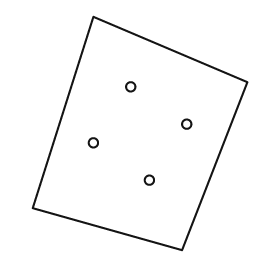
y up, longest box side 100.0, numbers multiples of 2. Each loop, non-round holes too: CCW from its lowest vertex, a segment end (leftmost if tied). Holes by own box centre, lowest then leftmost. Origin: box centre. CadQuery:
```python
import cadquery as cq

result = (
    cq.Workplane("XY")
    .moveTo(18.0, -50.0)
    .lineTo(46.0, 22.0)
    .lineTo(-20.0, 50.0)
    .lineTo(-46.0, -32.0)
    .close()
    .moveTo(4.0, -20.0)
    .circle(2.0)
    .moveTo(-20.0, -4.0)
    .circle(2.0)
    .moveTo(20.0, 4.0)
    .circle(2.0)
    .moveTo(-4.0, 20.0)
    .circle(2.0)
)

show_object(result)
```